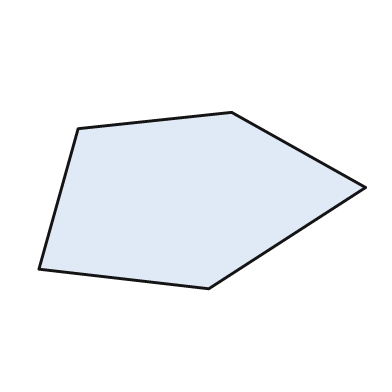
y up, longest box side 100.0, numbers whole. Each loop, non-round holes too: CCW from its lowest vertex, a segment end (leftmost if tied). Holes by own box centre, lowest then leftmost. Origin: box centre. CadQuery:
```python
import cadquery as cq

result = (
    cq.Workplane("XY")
    .moveTo(2.0, -27.0)
    .lineTo(50.0, 4.0)
    .lineTo(9.0, 27.0)
    .lineTo(-38.0, 22.0)
    .lineTo(-50.0, -21.0)
    .close()
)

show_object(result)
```